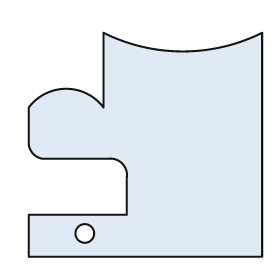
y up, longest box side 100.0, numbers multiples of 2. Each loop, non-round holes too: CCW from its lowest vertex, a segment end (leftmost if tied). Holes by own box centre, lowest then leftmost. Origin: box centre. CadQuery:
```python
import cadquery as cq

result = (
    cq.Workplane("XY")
    .moveTo(-50.0, -48.0)
    .lineTo(50.0, -48.0)
    .lineTo(50.0, 48.0)
    .threePointArc((16.0, 40.0), (-18.0, 48.0))
    .lineTo(-18.0, 16.0)
    .threePointArc((-34.0, 24.0), (-50.0, 16.0))
    .lineTo(-50.0, 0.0)
    .threePointArc((-48.0, -4.0), (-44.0, -6.0))
    .lineTo(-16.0, -6.0)
    .threePointArc((-10.0, -8.0), (-8.0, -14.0))
    .lineTo(-8.0, -30.0)
    .lineTo(-50.0, -30.0)
    .close()
    .moveTo(-26.0, -38.0)
    .circle(4.0)
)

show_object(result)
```